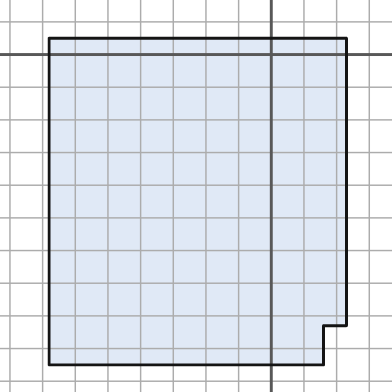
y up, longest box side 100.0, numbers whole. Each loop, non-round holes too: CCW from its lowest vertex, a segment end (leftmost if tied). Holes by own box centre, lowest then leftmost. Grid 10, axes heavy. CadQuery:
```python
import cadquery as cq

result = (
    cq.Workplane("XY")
    .moveTo(-68.0, -95.0)
    .lineTo(16.0, -95.0)
    .lineTo(16.0, -83.0)
    .lineTo(23.0, -83.0)
    .lineTo(23.0, 5.0)
    .lineTo(-68.0, 5.0)
    .close()
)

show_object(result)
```